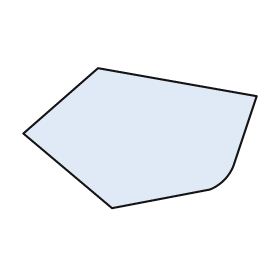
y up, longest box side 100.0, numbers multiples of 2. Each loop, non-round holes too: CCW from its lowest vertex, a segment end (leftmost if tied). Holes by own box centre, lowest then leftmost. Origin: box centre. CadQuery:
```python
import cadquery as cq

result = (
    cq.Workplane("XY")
    .moveTo(-12.0, -30.0)
    .lineTo(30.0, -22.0)
    .threePointArc((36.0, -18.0), (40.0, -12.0))
    .lineTo(50.0, 18.0)
    .lineTo(-18.0, 30.0)
    .lineTo(-50.0, 2.0)
    .close()
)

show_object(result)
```